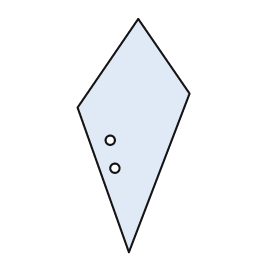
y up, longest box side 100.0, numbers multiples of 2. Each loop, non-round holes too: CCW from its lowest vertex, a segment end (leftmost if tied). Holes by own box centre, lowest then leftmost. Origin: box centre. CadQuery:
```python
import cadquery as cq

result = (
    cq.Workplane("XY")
    .moveTo(-2.0, -50.0)
    .lineTo(24.0, 18.0)
    .lineTo(2.0, 50.0)
    .lineTo(-24.0, 12.0)
    .close()
    .moveTo(-8.0, -14.0)
    .circle(2.0)
    .moveTo(-10.0, -2.0)
    .circle(2.0)
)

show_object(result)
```